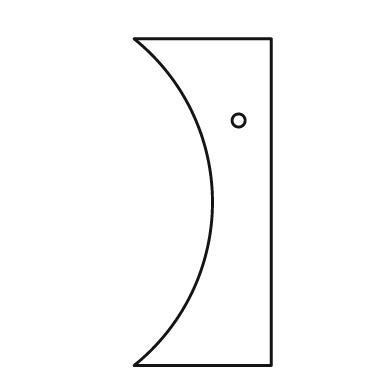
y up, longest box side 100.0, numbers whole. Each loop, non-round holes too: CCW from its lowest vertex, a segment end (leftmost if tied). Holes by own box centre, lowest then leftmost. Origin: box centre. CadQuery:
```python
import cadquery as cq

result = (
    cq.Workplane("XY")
    .moveTo(-21.0, -50.0)
    .lineTo(21.0, -50.0)
    .lineTo(21.0, 50.0)
    .lineTo(-21.0, 50.0)
    .threePointArc((3.0, 0.0), (-21.0, -50.0))
    .close()
    .moveTo(11.0, 25.0)
    .circle(2.0)
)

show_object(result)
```